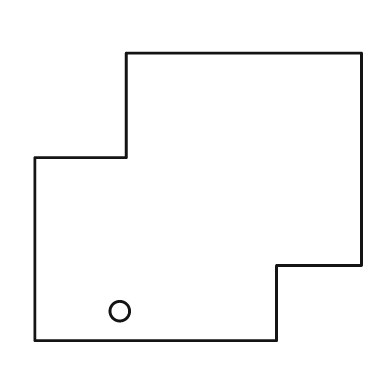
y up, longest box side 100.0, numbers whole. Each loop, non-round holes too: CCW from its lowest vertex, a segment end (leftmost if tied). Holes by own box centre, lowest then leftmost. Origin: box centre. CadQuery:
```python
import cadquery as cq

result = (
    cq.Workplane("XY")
    .moveTo(-50.0, -44.0)
    .lineTo(24.0, -44.0)
    .lineTo(24.0, -21.0)
    .lineTo(50.0, -21.0)
    .lineTo(50.0, 44.0)
    .lineTo(-22.0, 44.0)
    .lineTo(-22.0, 12.0)
    .lineTo(-50.0, 12.0)
    .close()
    .moveTo(-24.0, -35.0)
    .circle(3.0)
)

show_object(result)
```